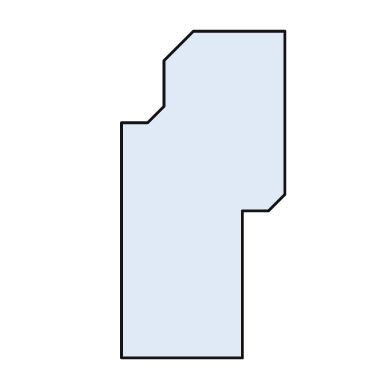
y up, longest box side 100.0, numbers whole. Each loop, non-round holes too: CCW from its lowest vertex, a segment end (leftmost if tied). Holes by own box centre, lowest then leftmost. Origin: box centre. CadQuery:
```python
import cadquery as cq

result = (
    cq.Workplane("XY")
    .moveTo(-25.0, -50.0)
    .lineTo(12.0, -50.0)
    .lineTo(12.0, -5.0)
    .lineTo(20.0, -5.0)
    .lineTo(25.0, 0.0)
    .lineTo(25.0, 50.0)
    .lineTo(-3.0, 50.0)
    .lineTo(-12.0, 41.0)
    .lineTo(-12.0, 27.0)
    .lineTo(-17.0, 22.0)
    .lineTo(-25.0, 22.0)
    .close()
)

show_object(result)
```